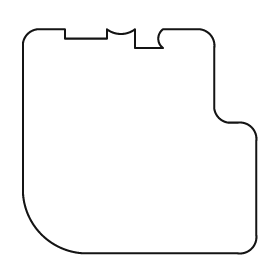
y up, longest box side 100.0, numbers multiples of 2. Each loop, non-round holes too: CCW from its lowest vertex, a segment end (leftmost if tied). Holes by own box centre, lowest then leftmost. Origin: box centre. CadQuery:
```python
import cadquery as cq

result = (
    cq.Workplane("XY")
    .moveTo(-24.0, -48.0)
    .lineTo(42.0, -48.0)
    .threePointArc((48.0, -46.0), (50.0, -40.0))
    .lineTo(50.0, 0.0)
    .threePointArc((48.0, 6.0), (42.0, 8.0))
    .lineTo(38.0, 8.0)
    .threePointArc((34.0, 10.0), (32.0, 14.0))
    .lineTo(32.0, 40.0)
    .threePointArc((30.0, 46.0), (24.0, 48.0))
    .lineTo(10.0, 48.0)
    .threePointArc((8.0, 44.0), (10.0, 40.0))
    .lineTo(-2.0, 40.0)
    .lineTo(-2.0, 48.0)
    .threePointArc((-8.0, 46.0), (-14.0, 48.0))
    .lineTo(-14.0, 44.0)
    .lineTo(-32.0, 44.0)
    .lineTo(-32.0, 48.0)
    .lineTo(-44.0, 48.0)
    .threePointArc((-48.0, 46.0), (-50.0, 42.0))
    .lineTo(-50.0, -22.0)
    .threePointArc((-42.0, -40.0), (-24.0, -48.0))
    .close()
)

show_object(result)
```